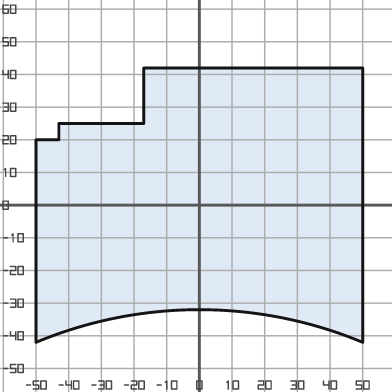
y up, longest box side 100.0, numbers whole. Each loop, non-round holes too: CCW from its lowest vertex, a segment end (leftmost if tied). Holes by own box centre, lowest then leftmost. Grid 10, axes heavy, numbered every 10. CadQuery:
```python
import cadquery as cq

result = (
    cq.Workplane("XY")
    .moveTo(-50.0, -42.0)
    .threePointArc((0.0, -32.0), (50.0, -42.0))
    .lineTo(50.0, 42.0)
    .lineTo(-17.0, 42.0)
    .lineTo(-17.0, 25.0)
    .lineTo(-43.0, 25.0)
    .lineTo(-43.0, 20.0)
    .lineTo(-50.0, 20.0)
    .close()
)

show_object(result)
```